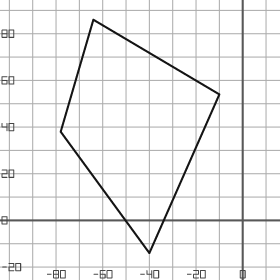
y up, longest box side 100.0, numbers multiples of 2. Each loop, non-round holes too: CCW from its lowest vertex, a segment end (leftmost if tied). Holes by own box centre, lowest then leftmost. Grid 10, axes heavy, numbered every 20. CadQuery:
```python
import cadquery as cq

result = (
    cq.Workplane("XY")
    .moveTo(-40.0, -14.0)
    .lineTo(-10.0, 54.0)
    .lineTo(-64.0, 86.0)
    .lineTo(-78.0, 38.0)
    .close()
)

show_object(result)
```